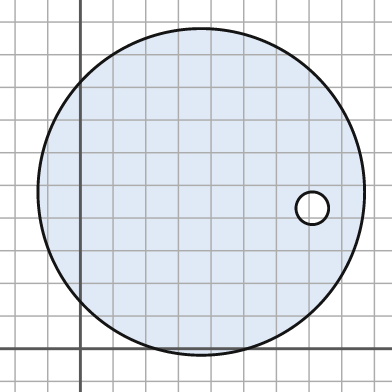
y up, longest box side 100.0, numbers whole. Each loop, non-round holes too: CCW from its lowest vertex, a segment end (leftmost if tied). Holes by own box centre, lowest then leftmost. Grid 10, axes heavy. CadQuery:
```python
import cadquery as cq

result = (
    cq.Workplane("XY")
    .moveTo(37.0, 48.0)
    .circle(50.0)
    .moveTo(71.0, 43.0)
    .circle(5.0)
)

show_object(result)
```